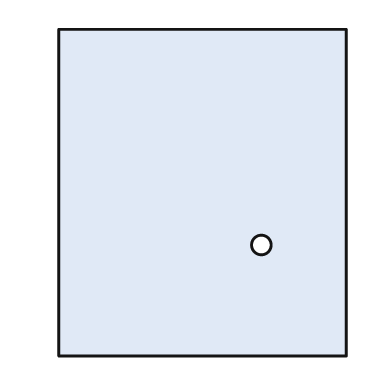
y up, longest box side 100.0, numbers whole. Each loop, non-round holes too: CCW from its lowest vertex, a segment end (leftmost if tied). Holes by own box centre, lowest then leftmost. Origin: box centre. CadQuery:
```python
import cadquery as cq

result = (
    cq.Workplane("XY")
    .moveTo(-44.0, -50.0)
    .lineTo(44.0, -50.0)
    .lineTo(44.0, 50.0)
    .lineTo(-44.0, 50.0)
    .close()
    .moveTo(18.0, -16.0)
    .circle(3.0)
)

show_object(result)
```